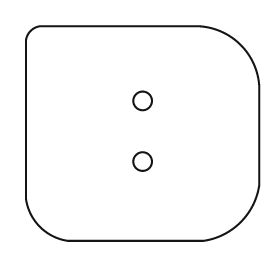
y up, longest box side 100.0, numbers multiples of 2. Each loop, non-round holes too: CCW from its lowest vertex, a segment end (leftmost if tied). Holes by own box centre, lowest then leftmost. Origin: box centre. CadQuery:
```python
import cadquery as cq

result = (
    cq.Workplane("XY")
    .moveTo(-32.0, -46.0)
    .lineTo(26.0, -46.0)
    .threePointArc((42.0, -38.0), (50.0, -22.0))
    .lineTo(50.0, 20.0)
    .threePointArc((42.0, 38.0), (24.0, 46.0))
    .lineTo(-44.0, 46.0)
    .threePointArc((-48.0, 44.0), (-50.0, 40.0))
    .lineTo(-50.0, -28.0)
    .threePointArc((-44.0, -40.0), (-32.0, -46.0))
    .close()
    .moveTo(0.0, -12.0)
    .circle(4.0)
    .moveTo(0.0, 14.0)
    .circle(4.0)
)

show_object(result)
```